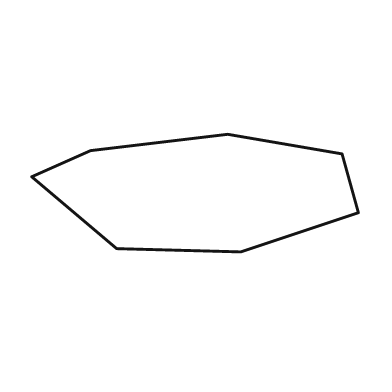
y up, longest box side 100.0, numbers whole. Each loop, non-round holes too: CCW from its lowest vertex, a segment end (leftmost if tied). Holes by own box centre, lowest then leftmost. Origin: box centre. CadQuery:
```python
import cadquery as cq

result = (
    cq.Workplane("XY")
    .moveTo(14.0, -18.0)
    .lineTo(50.0, -6.0)
    .lineTo(45.0, 12.0)
    .lineTo(10.0, 18.0)
    .lineTo(-32.0, 13.0)
    .lineTo(-50.0, 5.0)
    .lineTo(-24.0, -17.0)
    .close()
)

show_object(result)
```